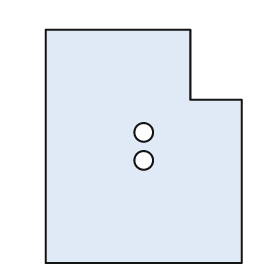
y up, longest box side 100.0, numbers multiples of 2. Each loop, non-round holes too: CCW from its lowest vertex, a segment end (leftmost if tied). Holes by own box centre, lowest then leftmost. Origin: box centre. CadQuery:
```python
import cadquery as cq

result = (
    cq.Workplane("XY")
    .moveTo(-42.0, -50.0)
    .lineTo(42.0, -50.0)
    .lineTo(42.0, 20.0)
    .lineTo(20.0, 20.0)
    .lineTo(20.0, 50.0)
    .lineTo(-42.0, 50.0)
    .close()
    .moveTo(0.0, -6.0)
    .circle(4.0)
    .moveTo(0.0, 6.0)
    .circle(4.0)
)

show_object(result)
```